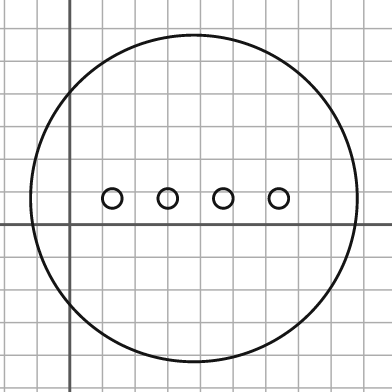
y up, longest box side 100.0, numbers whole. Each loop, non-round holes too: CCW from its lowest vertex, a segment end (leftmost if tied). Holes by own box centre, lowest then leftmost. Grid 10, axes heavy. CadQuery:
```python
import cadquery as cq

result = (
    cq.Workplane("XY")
    .moveTo(38.0, 8.0)
    .circle(50.0)
    .moveTo(13.0, 8.0)
    .circle(3.0)
    .moveTo(30.0, 8.0)
    .circle(3.0)
    .moveTo(47.0, 8.0)
    .circle(3.0)
    .moveTo(64.0, 8.0)
    .circle(3.0)
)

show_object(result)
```